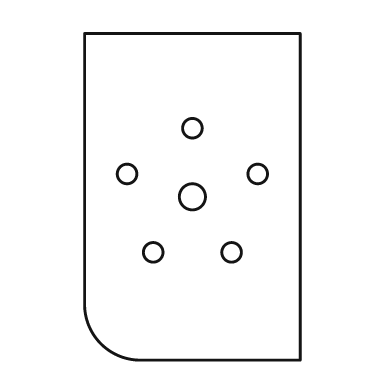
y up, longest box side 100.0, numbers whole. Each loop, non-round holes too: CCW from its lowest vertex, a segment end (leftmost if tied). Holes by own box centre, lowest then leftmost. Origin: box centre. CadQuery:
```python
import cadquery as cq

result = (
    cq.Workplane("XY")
    .moveTo(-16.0, -50.0)
    .lineTo(33.0, -50.0)
    .lineTo(33.0, 50.0)
    .lineTo(-33.0, 50.0)
    .lineTo(-33.0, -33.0)
    .threePointArc((-28.0, -45.0), (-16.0, -50.0))
    .close()
    .moveTo(-12.0, -17.0)
    .circle(3.0)
    .moveTo(12.0, -17.0)
    .circle(3.0)
    .moveTo(0.0, 0.0)
    .circle(4.0)
    .moveTo(-20.0, 7.0)
    .circle(3.0)
    .moveTo(20.0, 7.0)
    .circle(3.0)
    .moveTo(0.0, 21.0)
    .circle(3.0)
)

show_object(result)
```